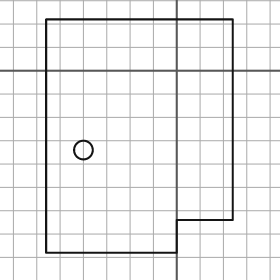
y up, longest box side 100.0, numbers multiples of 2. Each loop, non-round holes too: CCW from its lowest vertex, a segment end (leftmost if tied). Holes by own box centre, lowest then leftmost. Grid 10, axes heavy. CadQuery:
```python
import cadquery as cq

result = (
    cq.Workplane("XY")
    .moveTo(-56.0, -78.0)
    .lineTo(0.0, -78.0)
    .lineTo(0.0, -64.0)
    .lineTo(24.0, -64.0)
    .lineTo(24.0, 22.0)
    .lineTo(-56.0, 22.0)
    .close()
    .moveTo(-40.0, -34.0)
    .circle(4.0)
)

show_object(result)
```